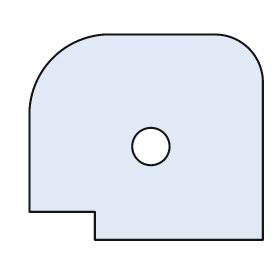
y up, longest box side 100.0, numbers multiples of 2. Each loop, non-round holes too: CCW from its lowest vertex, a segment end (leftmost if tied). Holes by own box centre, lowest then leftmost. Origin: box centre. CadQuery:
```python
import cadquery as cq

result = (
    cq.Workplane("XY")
    .moveTo(-22.0, -44.0)
    .lineTo(50.0, -44.0)
    .lineTo(50.0, 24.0)
    .threePointArc((44.0, 38.0), (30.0, 44.0))
    .lineTo(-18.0, 44.0)
    .threePointArc((-40.0, 34.0), (-50.0, 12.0))
    .lineTo(-50.0, -32.0)
    .lineTo(-22.0, -32.0)
    .close()
    .moveTo(2.0, -4.0)
    .circle(8.0)
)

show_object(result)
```